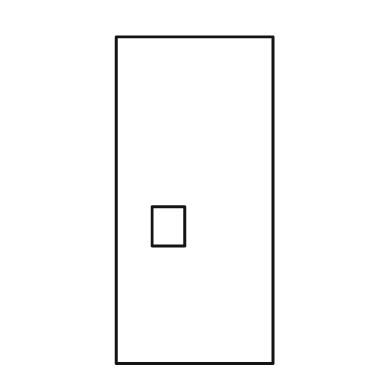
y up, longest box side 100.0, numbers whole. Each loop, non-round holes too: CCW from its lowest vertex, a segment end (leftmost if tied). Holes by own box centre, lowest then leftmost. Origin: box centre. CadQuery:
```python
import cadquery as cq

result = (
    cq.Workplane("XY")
    .moveTo(-24.0, -50.0)
    .lineTo(24.0, -50.0)
    .lineTo(24.0, 50.0)
    .lineTo(-24.0, 50.0)
    .close()
    .moveTo(-13.0, -14.0)
    .lineTo(-3.0, -14.0)
    .lineTo(-3.0, -2.0)
    .lineTo(-13.0, -2.0)
    .close()
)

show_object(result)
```